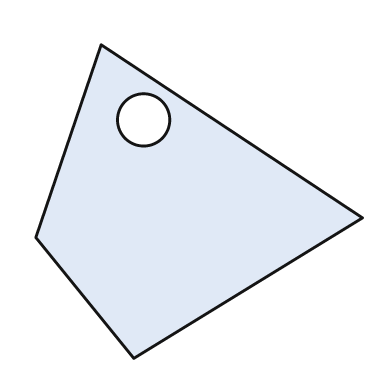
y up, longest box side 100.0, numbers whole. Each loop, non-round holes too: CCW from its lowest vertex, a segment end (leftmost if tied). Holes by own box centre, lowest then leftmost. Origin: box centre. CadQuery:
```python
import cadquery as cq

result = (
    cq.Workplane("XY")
    .moveTo(-20.0, -48.0)
    .lineTo(50.0, -5.0)
    .lineTo(-30.0, 48.0)
    .lineTo(-50.0, -11.0)
    .close()
    .moveTo(-17.0, 25.0)
    .circle(8.0)
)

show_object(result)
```